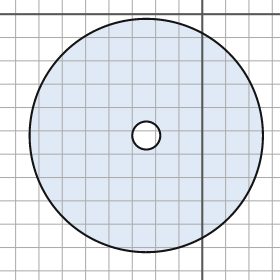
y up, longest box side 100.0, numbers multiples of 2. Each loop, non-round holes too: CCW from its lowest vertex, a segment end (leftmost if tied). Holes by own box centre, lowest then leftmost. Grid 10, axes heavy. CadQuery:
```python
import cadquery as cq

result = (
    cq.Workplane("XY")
    .moveTo(-24.0, -52.0)
    .circle(50.0)
    .moveTo(-24.0, -52.0)
    .circle(6.0)
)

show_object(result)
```